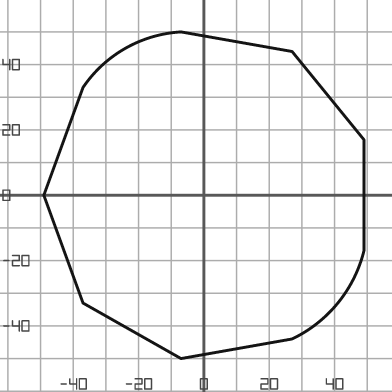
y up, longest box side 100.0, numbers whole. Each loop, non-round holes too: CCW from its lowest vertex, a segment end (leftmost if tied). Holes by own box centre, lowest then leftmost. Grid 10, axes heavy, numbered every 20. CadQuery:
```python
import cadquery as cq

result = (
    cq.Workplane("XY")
    .moveTo(-7.0, -50.0)
    .lineTo(27.0, -44.0)
    .threePointArc((41.0, -33.0), (49.0, -17.0))
    .lineTo(49.0, 17.0)
    .lineTo(27.0, 44.0)
    .lineTo(-7.0, 50.0)
    .threePointArc((-24.0, 45.0), (-37.0, 33.0))
    .lineTo(-49.0, 0.0)
    .lineTo(-37.0, -33.0)
    .close()
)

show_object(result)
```